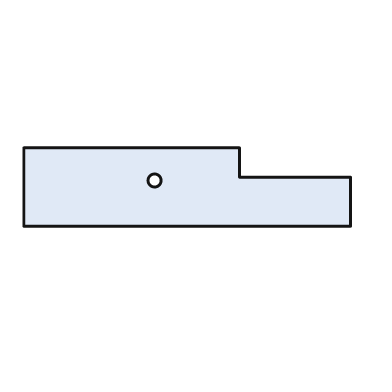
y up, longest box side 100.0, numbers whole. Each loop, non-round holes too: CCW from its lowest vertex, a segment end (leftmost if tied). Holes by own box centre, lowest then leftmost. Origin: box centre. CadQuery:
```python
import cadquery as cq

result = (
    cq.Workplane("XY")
    .moveTo(-50.0, -12.0)
    .lineTo(50.0, -12.0)
    .lineTo(50.0, 3.0)
    .lineTo(16.0, 3.0)
    .lineTo(16.0, 12.0)
    .lineTo(-50.0, 12.0)
    .close()
    .moveTo(-10.0, 2.0)
    .circle(2.0)
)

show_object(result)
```